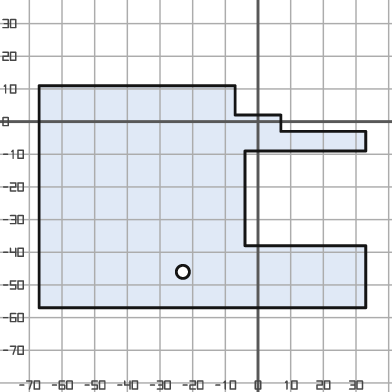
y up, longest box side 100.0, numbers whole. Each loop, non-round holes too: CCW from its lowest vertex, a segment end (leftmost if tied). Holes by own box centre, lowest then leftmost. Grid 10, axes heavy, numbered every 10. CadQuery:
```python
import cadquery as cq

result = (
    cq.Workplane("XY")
    .moveTo(-67.0, -57.0)
    .lineTo(33.0, -57.0)
    .lineTo(33.0, -38.0)
    .lineTo(-4.0, -38.0)
    .lineTo(-4.0, -9.0)
    .lineTo(33.0, -9.0)
    .lineTo(33.0, -3.0)
    .lineTo(7.0, -3.0)
    .lineTo(7.0, 2.0)
    .lineTo(-7.0, 2.0)
    .lineTo(-7.0, 11.0)
    .lineTo(-67.0, 11.0)
    .close()
    .moveTo(-23.0, -46.0)
    .circle(2.0)
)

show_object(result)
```